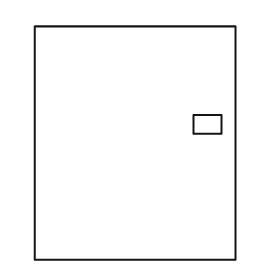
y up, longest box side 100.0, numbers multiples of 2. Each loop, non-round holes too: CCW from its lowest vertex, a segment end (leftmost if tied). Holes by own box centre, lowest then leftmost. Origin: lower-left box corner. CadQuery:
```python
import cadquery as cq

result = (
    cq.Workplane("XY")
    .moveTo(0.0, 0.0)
    .lineTo(86.0, 0.0)
    .lineTo(86.0, 100.0)
    .lineTo(0.0, 100.0)
    .close()
    .moveTo(68.0, 54.0)
    .lineTo(80.0, 54.0)
    .lineTo(80.0, 62.0)
    .lineTo(68.0, 62.0)
    .close()
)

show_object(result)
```